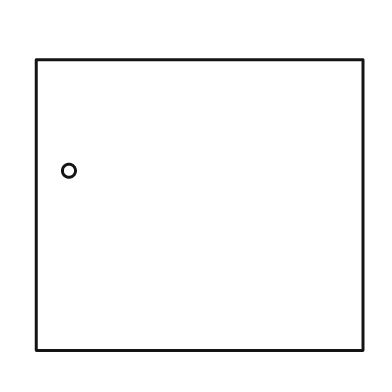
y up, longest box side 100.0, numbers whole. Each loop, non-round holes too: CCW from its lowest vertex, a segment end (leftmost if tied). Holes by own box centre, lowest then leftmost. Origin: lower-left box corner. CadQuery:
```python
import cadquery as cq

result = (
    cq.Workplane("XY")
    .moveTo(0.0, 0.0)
    .lineTo(100.0, 0.0)
    .lineTo(100.0, 89.0)
    .lineTo(0.0, 89.0)
    .close()
    .moveTo(10.0, 55.0)
    .circle(2.0)
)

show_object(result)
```